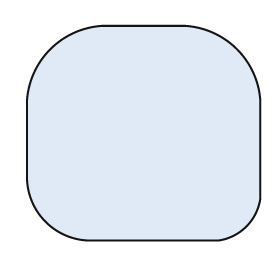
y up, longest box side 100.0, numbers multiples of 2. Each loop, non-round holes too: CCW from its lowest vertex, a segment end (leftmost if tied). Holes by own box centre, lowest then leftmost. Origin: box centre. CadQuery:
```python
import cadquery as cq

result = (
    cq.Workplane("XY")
    .moveTo(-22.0, -46.0)
    .lineTo(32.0, -46.0)
    .threePointArc((44.0, -40.0), (50.0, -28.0))
    .lineTo(50.0, 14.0)
    .threePointArc((40.0, 36.0), (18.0, 46.0))
    .lineTo(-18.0, 46.0)
    .threePointArc((-40.0, 36.0), (-50.0, 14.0))
    .lineTo(-50.0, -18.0)
    .threePointArc((-42.0, -38.0), (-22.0, -46.0))
    .close()
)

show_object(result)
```